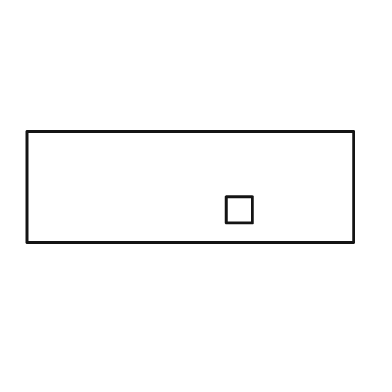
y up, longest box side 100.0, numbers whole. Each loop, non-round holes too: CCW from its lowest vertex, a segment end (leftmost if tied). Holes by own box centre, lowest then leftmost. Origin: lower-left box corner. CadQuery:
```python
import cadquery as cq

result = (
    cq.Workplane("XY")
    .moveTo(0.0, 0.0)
    .lineTo(100.0, 0.0)
    .lineTo(100.0, 34.0)
    .lineTo(0.0, 34.0)
    .close()
    .moveTo(61.0, 6.0)
    .lineTo(69.0, 6.0)
    .lineTo(69.0, 14.0)
    .lineTo(61.0, 14.0)
    .close()
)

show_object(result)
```